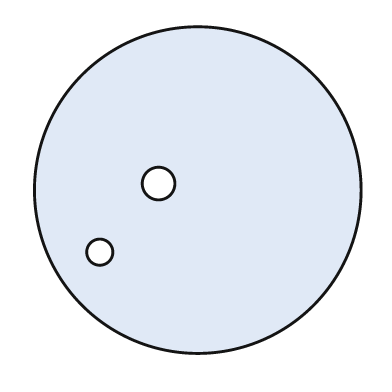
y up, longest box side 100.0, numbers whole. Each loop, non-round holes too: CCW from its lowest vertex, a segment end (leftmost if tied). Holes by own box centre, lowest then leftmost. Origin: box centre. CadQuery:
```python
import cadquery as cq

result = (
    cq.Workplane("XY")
    .moveTo(0.0, 0.0)
    .circle(50.0)
    .moveTo(-30.0, -19.0)
    .circle(4.0)
    .moveTo(-12.0, 2.0)
    .circle(5.0)
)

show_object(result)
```